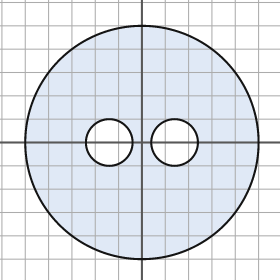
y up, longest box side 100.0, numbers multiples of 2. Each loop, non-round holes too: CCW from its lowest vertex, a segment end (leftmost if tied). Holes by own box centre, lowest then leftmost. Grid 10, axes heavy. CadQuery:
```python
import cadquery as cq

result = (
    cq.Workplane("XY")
    .moveTo(0.0, 0.0)
    .circle(50.0)
    .moveTo(-14.0, 0.0)
    .circle(10.0)
    .moveTo(14.0, 0.0)
    .circle(10.0)
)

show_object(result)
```